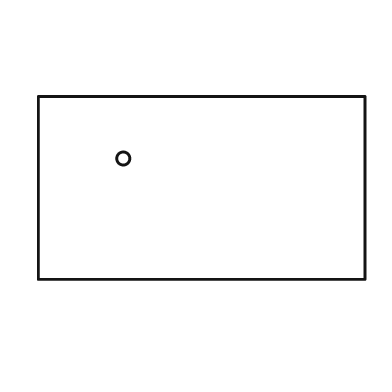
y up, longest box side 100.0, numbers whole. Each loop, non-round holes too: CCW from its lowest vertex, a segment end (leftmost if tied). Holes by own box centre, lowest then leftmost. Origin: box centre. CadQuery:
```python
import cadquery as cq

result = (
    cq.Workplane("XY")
    .moveTo(-50.0, -28.0)
    .lineTo(50.0, -28.0)
    .lineTo(50.0, 28.0)
    .lineTo(-50.0, 28.0)
    .close()
    .moveTo(-24.0, 9.0)
    .circle(2.0)
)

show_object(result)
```